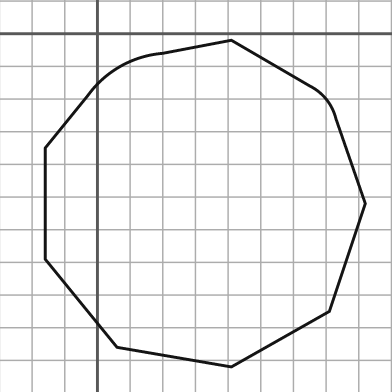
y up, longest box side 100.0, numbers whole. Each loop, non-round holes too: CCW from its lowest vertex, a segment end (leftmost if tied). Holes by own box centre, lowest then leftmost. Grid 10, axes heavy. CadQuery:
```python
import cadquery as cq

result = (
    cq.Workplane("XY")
    .moveTo(41.0, -102.0)
    .lineTo(71.0, -85.0)
    .lineTo(82.0, -52.0)
    .lineTo(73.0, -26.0)
    .threePointArc((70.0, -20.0), (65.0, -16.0))
    .lineTo(41.0, -2.0)
    .lineTo(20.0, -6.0)
    .threePointArc((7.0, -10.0), (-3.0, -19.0))
    .lineTo(-16.0, -35.0)
    .lineTo(-16.0, -69.0)
    .lineTo(6.0, -96.0)
    .close()
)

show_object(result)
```